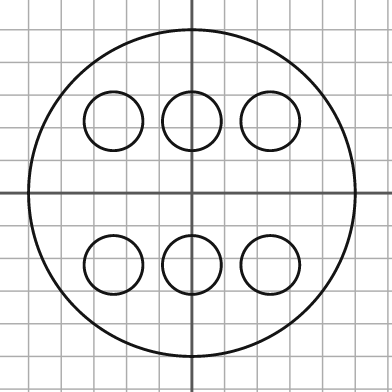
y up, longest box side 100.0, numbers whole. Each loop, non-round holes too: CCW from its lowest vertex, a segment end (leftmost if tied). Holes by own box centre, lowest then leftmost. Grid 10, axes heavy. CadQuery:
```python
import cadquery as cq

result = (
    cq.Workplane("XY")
    .moveTo(0.0, 0.0)
    .circle(50.0)
    .moveTo(-24.0, -22.0)
    .circle(9.0)
    .moveTo(0.0, -22.0)
    .circle(9.0)
    .moveTo(24.0, -22.0)
    .circle(9.0)
    .moveTo(-24.0, 22.0)
    .circle(9.0)
    .moveTo(0.0, 22.0)
    .circle(9.0)
    .moveTo(24.0, 22.0)
    .circle(9.0)
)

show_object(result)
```